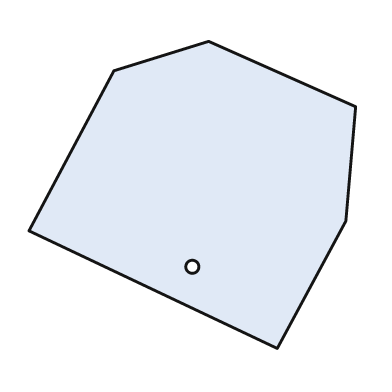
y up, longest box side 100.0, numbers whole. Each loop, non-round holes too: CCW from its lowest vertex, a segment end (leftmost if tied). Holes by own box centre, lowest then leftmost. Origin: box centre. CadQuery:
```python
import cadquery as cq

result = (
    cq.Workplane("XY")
    .moveTo(26.0, -47.0)
    .lineTo(47.0, -8.0)
    .lineTo(50.0, 27.0)
    .lineTo(5.0, 47.0)
    .lineTo(-24.0, 38.0)
    .lineTo(-50.0, -11.0)
    .close()
    .moveTo(0.0, -22.0)
    .circle(2.0)
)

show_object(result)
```